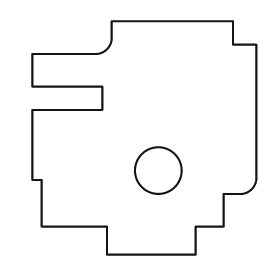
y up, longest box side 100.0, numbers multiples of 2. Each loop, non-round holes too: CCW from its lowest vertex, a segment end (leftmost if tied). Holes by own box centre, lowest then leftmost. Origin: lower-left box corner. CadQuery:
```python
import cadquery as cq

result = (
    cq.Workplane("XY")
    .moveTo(32.0, 0.0)
    .lineTo(70.0, 0.0)
    .lineTo(70.0, 12.0)
    .lineTo(82.0, 12.0)
    .lineTo(82.0, 26.0)
    .lineTo(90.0, 26.0)
    .threePointArc((94.0, 28.0), (96.0, 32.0))
    .lineTo(96.0, 90.0)
    .lineTo(86.0, 90.0)
    .lineTo(86.0, 100.0)
    .lineTo(34.0, 100.0)
    .lineTo(34.0, 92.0)
    .threePointArc((32.0, 88.0), (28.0, 86.0))
    .lineTo(0.0, 86.0)
    .lineTo(0.0, 72.0)
    .lineTo(30.0, 72.0)
    .lineTo(30.0, 62.0)
    .lineTo(0.0, 62.0)
    .lineTo(0.0, 32.0)
    .lineTo(4.0, 32.0)
    .lineTo(4.0, 12.0)
    .lineTo(32.0, 12.0)
    .close()
    .moveTo(54.0, 36.0)
    .circle(10.0)
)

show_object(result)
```